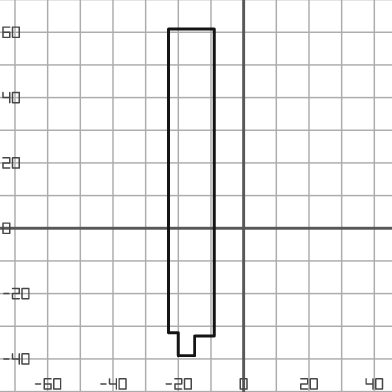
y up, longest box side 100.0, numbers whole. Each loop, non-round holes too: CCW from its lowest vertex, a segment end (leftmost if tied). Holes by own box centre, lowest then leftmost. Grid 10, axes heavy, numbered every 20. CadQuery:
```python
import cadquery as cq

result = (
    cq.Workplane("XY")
    .moveTo(-20.0, -39.0)
    .lineTo(-15.0, -39.0)
    .lineTo(-15.0, -33.0)
    .lineTo(-9.0, -33.0)
    .lineTo(-9.0, 61.0)
    .lineTo(-23.0, 61.0)
    .lineTo(-23.0, -32.0)
    .lineTo(-20.0, -32.0)
    .close()
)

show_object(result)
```